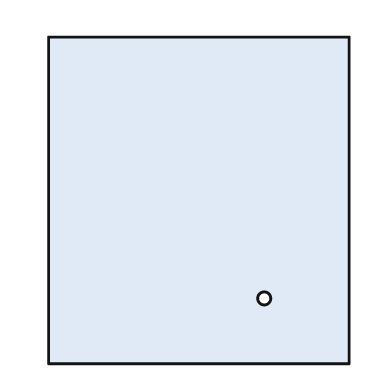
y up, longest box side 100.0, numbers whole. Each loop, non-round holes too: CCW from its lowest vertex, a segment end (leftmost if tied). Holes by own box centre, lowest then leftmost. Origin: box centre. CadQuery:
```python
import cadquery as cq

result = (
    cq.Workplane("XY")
    .moveTo(-46.0, -50.0)
    .lineTo(46.0, -50.0)
    .lineTo(46.0, 50.0)
    .lineTo(-46.0, 50.0)
    .close()
    .moveTo(20.0, -30.0)
    .circle(2.0)
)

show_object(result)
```